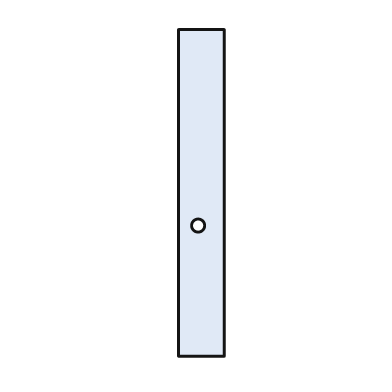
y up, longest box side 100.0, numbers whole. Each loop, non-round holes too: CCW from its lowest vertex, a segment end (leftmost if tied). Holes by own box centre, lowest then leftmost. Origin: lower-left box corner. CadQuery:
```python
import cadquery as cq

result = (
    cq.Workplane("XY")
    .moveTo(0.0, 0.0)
    .lineTo(14.0, 0.0)
    .lineTo(14.0, 100.0)
    .lineTo(0.0, 100.0)
    .close()
    .moveTo(6.0, 40.0)
    .circle(2.0)
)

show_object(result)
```